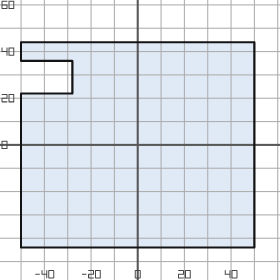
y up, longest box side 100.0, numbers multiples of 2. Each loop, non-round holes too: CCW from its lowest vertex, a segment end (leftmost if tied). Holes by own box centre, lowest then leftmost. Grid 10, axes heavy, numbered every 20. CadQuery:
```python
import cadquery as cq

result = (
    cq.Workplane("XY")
    .moveTo(-50.0, -44.0)
    .lineTo(50.0, -44.0)
    .lineTo(50.0, 44.0)
    .lineTo(-50.0, 44.0)
    .lineTo(-50.0, 36.0)
    .lineTo(-28.0, 36.0)
    .lineTo(-28.0, 22.0)
    .lineTo(-50.0, 22.0)
    .close()
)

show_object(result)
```